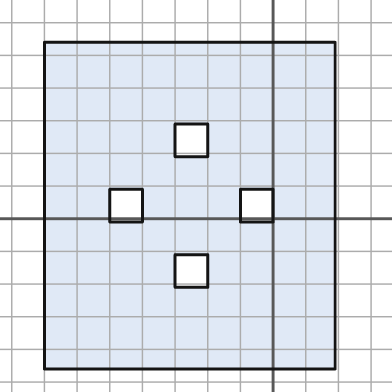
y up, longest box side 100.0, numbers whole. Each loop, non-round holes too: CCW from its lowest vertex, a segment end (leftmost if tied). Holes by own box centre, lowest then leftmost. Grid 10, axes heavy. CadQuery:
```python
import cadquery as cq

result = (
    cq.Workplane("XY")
    .moveTo(-70.0, -46.0)
    .lineTo(19.0, -46.0)
    .lineTo(19.0, 54.0)
    .lineTo(-70.0, 54.0)
    .close()
    .moveTo(-30.0, -21.0)
    .lineTo(-20.0, -21.0)
    .lineTo(-20.0, -11.0)
    .lineTo(-30.0, -11.0)
    .close()
    .moveTo(-50.0, -1.0)
    .lineTo(-40.0, -1.0)
    .lineTo(-40.0, 9.0)
    .lineTo(-50.0, 9.0)
    .close()
    .moveTo(-10.0, -1.0)
    .lineTo(0.0, -1.0)
    .lineTo(0.0, 9.0)
    .lineTo(-10.0, 9.0)
    .close()
    .moveTo(-30.0, 19.0)
    .lineTo(-20.0, 19.0)
    .lineTo(-20.0, 29.0)
    .lineTo(-30.0, 29.0)
    .close()
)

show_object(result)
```